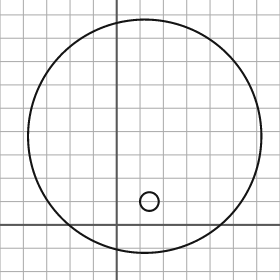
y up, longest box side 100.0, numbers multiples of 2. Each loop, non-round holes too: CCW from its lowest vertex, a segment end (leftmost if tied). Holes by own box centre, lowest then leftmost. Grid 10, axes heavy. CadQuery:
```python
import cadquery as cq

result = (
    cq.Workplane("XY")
    .moveTo(12.0, 38.0)
    .circle(50.0)
    .moveTo(14.0, 10.0)
    .circle(4.0)
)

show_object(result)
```